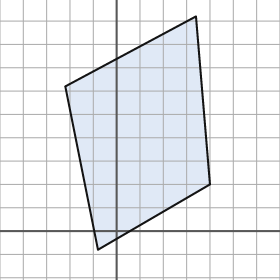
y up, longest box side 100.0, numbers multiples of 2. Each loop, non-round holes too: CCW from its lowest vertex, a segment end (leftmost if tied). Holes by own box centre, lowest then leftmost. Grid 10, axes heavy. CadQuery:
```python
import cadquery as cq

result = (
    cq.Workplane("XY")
    .moveTo(-8.0, -8.0)
    .lineTo(40.0, 20.0)
    .lineTo(34.0, 92.0)
    .lineTo(-22.0, 62.0)
    .close()
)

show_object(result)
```